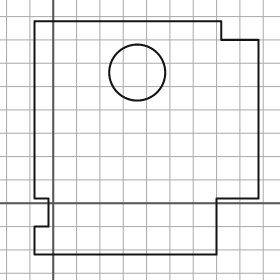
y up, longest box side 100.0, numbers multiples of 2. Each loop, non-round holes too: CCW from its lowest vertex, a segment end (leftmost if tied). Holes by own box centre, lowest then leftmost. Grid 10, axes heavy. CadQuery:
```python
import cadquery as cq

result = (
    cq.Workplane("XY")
    .moveTo(-8.0, -22.0)
    .lineTo(70.0, -22.0)
    .lineTo(70.0, 2.0)
    .lineTo(88.0, 2.0)
    .lineTo(88.0, 70.0)
    .lineTo(72.0, 70.0)
    .lineTo(72.0, 78.0)
    .lineTo(-8.0, 78.0)
    .lineTo(-8.0, 2.0)
    .lineTo(-2.0, 2.0)
    .lineTo(-2.0, -10.0)
    .lineTo(-8.0, -10.0)
    .close()
    .moveTo(36.0, 56.0)
    .circle(12.0)
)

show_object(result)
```